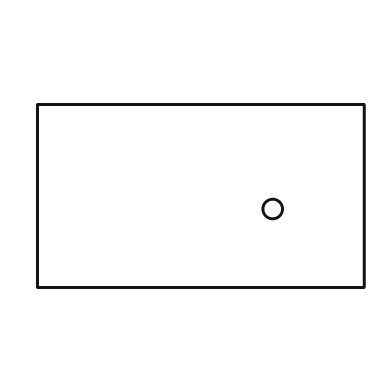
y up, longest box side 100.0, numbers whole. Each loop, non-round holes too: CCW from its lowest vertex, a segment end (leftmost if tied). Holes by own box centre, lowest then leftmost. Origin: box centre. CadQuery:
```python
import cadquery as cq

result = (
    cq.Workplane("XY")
    .moveTo(-50.0, -28.0)
    .lineTo(50.0, -28.0)
    .lineTo(50.0, 28.0)
    .lineTo(-50.0, 28.0)
    .close()
    .moveTo(22.0, -4.0)
    .circle(3.0)
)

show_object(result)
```